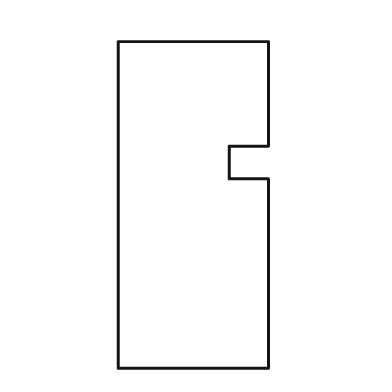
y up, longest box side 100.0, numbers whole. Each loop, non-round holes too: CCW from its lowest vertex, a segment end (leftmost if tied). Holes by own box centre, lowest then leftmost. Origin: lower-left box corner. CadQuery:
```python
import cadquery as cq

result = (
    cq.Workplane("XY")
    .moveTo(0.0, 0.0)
    .lineTo(46.0, 0.0)
    .lineTo(46.0, 58.0)
    .lineTo(34.0, 58.0)
    .lineTo(34.0, 68.0)
    .lineTo(46.0, 68.0)
    .lineTo(46.0, 100.0)
    .lineTo(0.0, 100.0)
    .close()
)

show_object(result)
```